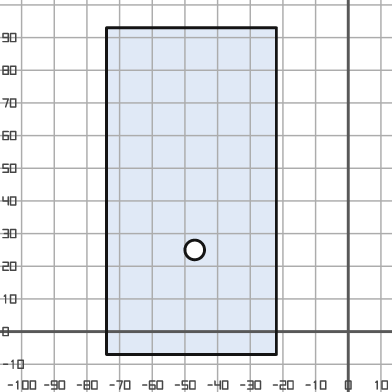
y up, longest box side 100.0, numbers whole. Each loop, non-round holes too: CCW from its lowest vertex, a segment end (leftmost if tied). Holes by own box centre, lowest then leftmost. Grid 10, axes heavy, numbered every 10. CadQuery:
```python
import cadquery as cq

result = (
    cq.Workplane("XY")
    .moveTo(-74.0, -7.0)
    .lineTo(-22.0, -7.0)
    .lineTo(-22.0, 93.0)
    .lineTo(-74.0, 93.0)
    .close()
    .moveTo(-47.0, 25.0)
    .circle(3.0)
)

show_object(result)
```